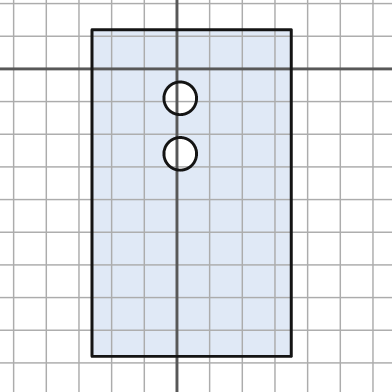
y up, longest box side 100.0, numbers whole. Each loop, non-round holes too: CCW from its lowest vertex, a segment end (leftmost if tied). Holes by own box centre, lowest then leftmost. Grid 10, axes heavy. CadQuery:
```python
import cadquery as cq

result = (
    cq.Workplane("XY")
    .moveTo(-26.0, -88.0)
    .lineTo(35.0, -88.0)
    .lineTo(35.0, 12.0)
    .lineTo(-26.0, 12.0)
    .close()
    .moveTo(1.0, -26.0)
    .circle(5.0)
    .moveTo(1.0, -9.0)
    .circle(5.0)
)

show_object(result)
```